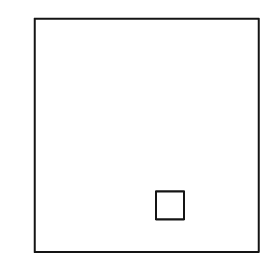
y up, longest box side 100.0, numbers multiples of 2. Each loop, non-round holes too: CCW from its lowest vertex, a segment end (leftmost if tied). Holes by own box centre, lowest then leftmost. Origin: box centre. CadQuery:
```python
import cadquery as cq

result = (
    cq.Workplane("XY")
    .moveTo(-48.0, -50.0)
    .lineTo(48.0, -50.0)
    .lineTo(48.0, 50.0)
    .lineTo(-48.0, 50.0)
    .close()
    .moveTo(4.0, -36.0)
    .lineTo(16.0, -36.0)
    .lineTo(16.0, -24.0)
    .lineTo(4.0, -24.0)
    .close()
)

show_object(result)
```